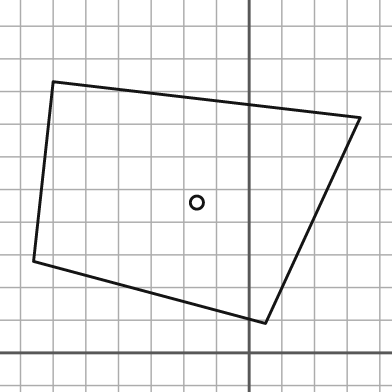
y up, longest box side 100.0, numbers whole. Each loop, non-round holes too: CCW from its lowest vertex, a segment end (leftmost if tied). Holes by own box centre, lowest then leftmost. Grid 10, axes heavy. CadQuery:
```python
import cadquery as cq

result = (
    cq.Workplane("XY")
    .moveTo(5.0, 9.0)
    .lineTo(34.0, 72.0)
    .lineTo(-60.0, 83.0)
    .lineTo(-66.0, 28.0)
    .close()
    .moveTo(-16.0, 46.0)
    .circle(2.0)
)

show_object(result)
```